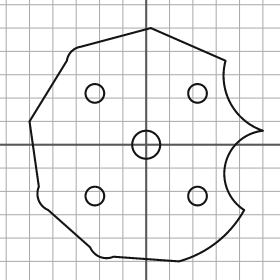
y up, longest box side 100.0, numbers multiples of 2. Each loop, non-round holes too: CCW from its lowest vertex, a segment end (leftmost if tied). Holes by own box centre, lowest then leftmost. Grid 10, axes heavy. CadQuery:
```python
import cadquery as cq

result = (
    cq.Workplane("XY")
    .moveTo(14.0, -50.0)
    .threePointArc((30.0, -42.0), (42.0, -28.0))
    .threePointArc((34.0, -8.0), (50.0, 6.0))
    .threePointArc((36.0, 18.0), (34.0, 36.0))
    .lineTo(2.0, 50.0)
    .lineTo(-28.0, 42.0)
    .threePointArc((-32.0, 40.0), (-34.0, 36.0))
    .lineTo(-50.0, 10.0)
    .lineTo(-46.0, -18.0)
    .threePointArc((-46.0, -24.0), (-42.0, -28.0))
    .lineTo(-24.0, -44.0)
    .threePointArc((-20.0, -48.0), (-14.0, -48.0))
    .close()
    .moveTo(-22.0, -22.0)
    .circle(4.0)
    .moveTo(22.0, -22.0)
    .circle(4.0)
    .moveTo(0.0, 0.0)
    .circle(6.0)
    .moveTo(-22.0, 22.0)
    .circle(4.0)
    .moveTo(22.0, 22.0)
    .circle(4.0)
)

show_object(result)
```